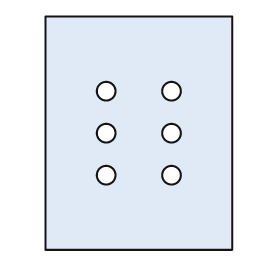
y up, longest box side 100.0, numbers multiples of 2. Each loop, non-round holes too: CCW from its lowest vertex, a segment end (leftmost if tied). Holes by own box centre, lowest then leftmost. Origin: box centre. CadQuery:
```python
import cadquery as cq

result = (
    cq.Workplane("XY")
    .moveTo(-40.0, -50.0)
    .lineTo(40.0, -50.0)
    .lineTo(40.0, 50.0)
    .lineTo(-40.0, 50.0)
    .close()
    .moveTo(-14.0, -18.0)
    .circle(4.0)
    .moveTo(14.0, -18.0)
    .circle(4.0)
    .moveTo(-14.0, 0.0)
    .circle(4.0)
    .moveTo(14.0, 0.0)
    .circle(4.0)
    .moveTo(-14.0, 18.0)
    .circle(4.0)
    .moveTo(14.0, 18.0)
    .circle(4.0)
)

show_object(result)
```